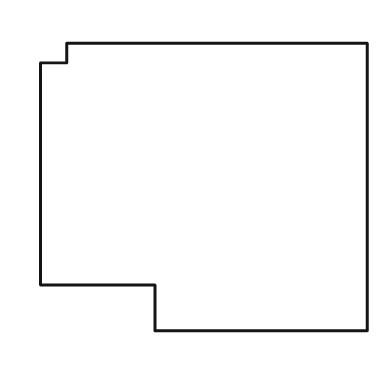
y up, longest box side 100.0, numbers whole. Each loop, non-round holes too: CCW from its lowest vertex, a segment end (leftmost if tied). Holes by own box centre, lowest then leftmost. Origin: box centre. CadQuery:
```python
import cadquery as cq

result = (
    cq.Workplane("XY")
    .moveTo(-15.0, -44.0)
    .lineTo(50.0, -44.0)
    .lineTo(50.0, 44.0)
    .lineTo(-42.0, 44.0)
    .lineTo(-42.0, 38.0)
    .lineTo(-50.0, 38.0)
    .lineTo(-50.0, -30.0)
    .lineTo(-15.0, -30.0)
    .close()
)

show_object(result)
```